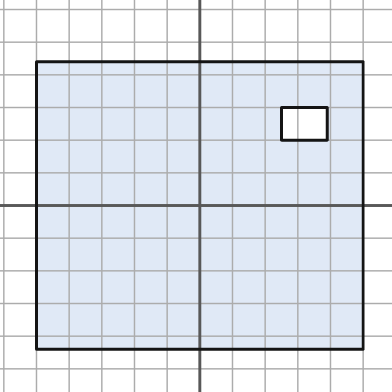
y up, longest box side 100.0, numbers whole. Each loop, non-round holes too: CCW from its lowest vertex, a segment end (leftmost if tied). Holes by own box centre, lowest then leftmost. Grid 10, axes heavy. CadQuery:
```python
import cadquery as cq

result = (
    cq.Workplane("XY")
    .moveTo(-50.0, -44.0)
    .lineTo(50.0, -44.0)
    .lineTo(50.0, 44.0)
    .lineTo(-50.0, 44.0)
    .close()
    .moveTo(25.0, 20.0)
    .lineTo(39.0, 20.0)
    .lineTo(39.0, 30.0)
    .lineTo(25.0, 30.0)
    .close()
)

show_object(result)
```